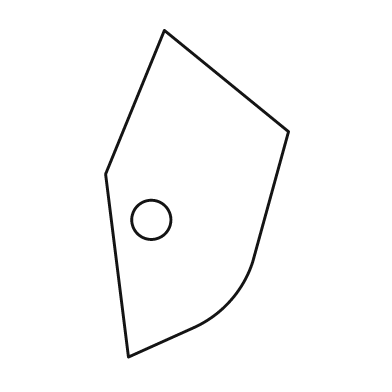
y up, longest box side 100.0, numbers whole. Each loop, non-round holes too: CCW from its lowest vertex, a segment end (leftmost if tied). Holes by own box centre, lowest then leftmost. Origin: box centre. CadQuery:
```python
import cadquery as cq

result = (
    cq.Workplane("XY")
    .moveTo(-21.0, -50.0)
    .lineTo(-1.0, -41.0)
    .threePointArc((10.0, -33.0), (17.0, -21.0))
    .lineTo(28.0, 19.0)
    .lineTo(-10.0, 50.0)
    .lineTo(-28.0, 6.0)
    .close()
    .moveTo(-14.0, -8.0)
    .circle(6.0)
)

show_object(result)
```